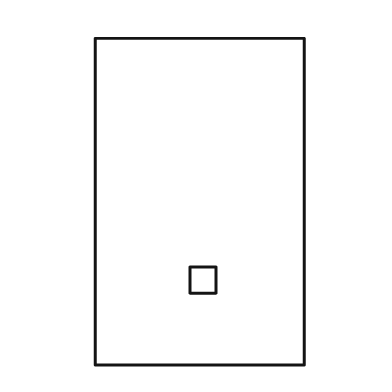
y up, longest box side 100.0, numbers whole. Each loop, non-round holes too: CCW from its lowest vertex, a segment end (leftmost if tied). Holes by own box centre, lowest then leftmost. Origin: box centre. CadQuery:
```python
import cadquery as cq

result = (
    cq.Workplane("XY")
    .moveTo(-32.0, -50.0)
    .lineTo(32.0, -50.0)
    .lineTo(32.0, 50.0)
    .lineTo(-32.0, 50.0)
    .close()
    .moveTo(-3.0, -28.0)
    .lineTo(5.0, -28.0)
    .lineTo(5.0, -20.0)
    .lineTo(-3.0, -20.0)
    .close()
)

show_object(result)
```